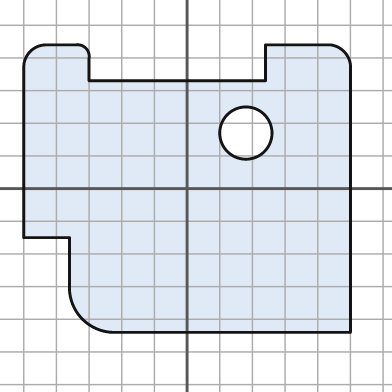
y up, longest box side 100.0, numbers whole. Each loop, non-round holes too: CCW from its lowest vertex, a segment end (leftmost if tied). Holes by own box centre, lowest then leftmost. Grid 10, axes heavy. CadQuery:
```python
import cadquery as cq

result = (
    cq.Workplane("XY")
    .moveTo(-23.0, -44.0)
    .lineTo(50.0, -44.0)
    .lineTo(50.0, 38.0)
    .threePointArc((48.0, 42.0), (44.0, 44.0))
    .lineTo(24.0, 44.0)
    .lineTo(24.0, 33.0)
    .lineTo(-30.0, 33.0)
    .lineTo(-30.0, 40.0)
    .threePointArc((-31.0, 43.0), (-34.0, 44.0))
    .lineTo(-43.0, 44.0)
    .threePointArc((-48.0, 42.0), (-50.0, 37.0))
    .lineTo(-50.0, -15.0)
    .lineTo(-36.0, -15.0)
    .lineTo(-36.0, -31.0)
    .threePointArc((-32.0, -40.0), (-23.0, -44.0))
    .close()
    .moveTo(18.0, 17.0)
    .circle(8.0)
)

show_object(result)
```